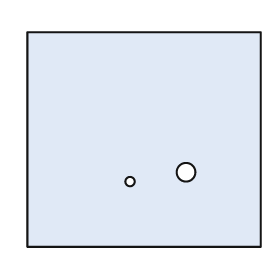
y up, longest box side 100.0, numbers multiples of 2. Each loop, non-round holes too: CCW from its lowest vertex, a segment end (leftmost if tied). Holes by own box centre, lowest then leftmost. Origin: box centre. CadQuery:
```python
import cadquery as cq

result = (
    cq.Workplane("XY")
    .moveTo(-50.0, -46.0)
    .lineTo(50.0, -46.0)
    .lineTo(50.0, 46.0)
    .lineTo(-50.0, 46.0)
    .close()
    .moveTo(-6.0, -18.0)
    .circle(2.0)
    .moveTo(18.0, -14.0)
    .circle(4.0)
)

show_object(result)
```